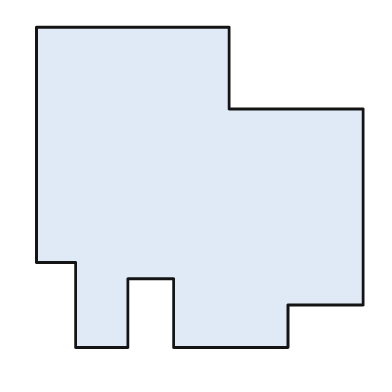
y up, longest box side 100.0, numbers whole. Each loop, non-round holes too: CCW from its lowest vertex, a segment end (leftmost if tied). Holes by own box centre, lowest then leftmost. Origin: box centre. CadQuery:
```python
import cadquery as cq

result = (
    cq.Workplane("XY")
    .moveTo(-38.0, -49.0)
    .lineTo(-22.0, -49.0)
    .lineTo(-22.0, -28.0)
    .lineTo(-8.0, -28.0)
    .lineTo(-8.0, -49.0)
    .lineTo(27.0, -49.0)
    .lineTo(27.0, -36.0)
    .lineTo(50.0, -36.0)
    .lineTo(50.0, 24.0)
    .lineTo(9.0, 24.0)
    .lineTo(9.0, 49.0)
    .lineTo(-50.0, 49.0)
    .lineTo(-50.0, -23.0)
    .lineTo(-38.0, -23.0)
    .close()
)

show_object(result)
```